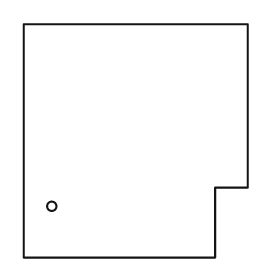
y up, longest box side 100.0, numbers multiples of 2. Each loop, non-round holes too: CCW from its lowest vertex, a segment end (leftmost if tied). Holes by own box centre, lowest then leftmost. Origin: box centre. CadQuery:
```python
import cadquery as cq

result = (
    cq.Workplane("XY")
    .moveTo(-48.0, -50.0)
    .lineTo(34.0, -50.0)
    .lineTo(34.0, -20.0)
    .lineTo(48.0, -20.0)
    .lineTo(48.0, 50.0)
    .lineTo(-48.0, 50.0)
    .close()
    .moveTo(-36.0, -28.0)
    .circle(2.0)
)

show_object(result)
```